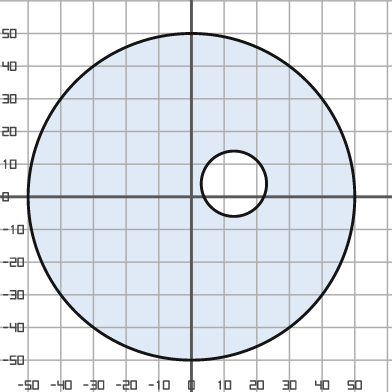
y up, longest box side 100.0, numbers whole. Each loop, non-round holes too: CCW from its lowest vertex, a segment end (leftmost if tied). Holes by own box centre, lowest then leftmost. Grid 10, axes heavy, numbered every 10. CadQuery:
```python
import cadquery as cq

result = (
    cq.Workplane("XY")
    .moveTo(0.0, 0.0)
    .circle(50.0)
    .moveTo(13.0, 4.0)
    .circle(10.0)
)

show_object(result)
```